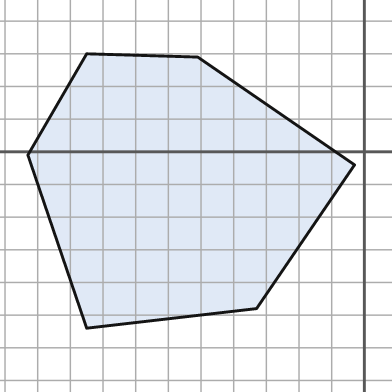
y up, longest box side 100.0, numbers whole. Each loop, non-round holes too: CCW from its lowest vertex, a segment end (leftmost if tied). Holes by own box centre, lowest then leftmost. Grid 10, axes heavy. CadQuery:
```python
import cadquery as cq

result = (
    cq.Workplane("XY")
    .moveTo(-85.0, -54.0)
    .lineTo(-33.0, -48.0)
    .lineTo(-3.0, -4.0)
    .lineTo(-51.0, 29.0)
    .lineTo(-85.0, 30.0)
    .lineTo(-103.0, -1.0)
    .close()
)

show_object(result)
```